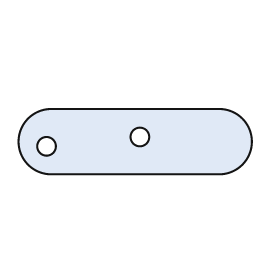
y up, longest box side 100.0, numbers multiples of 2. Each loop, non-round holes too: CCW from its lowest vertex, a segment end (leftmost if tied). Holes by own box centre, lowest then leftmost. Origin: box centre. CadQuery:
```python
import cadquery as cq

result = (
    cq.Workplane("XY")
    .moveTo(-36.0, -14.0)
    .lineTo(36.0, -14.0)
    .threePointArc((50.0, 0.0), (36.0, 14.0))
    .lineTo(-36.0, 14.0)
    .threePointArc((-50.0, 0.0), (-36.0, -14.0))
    .close()
    .moveTo(-38.0, -2.0)
    .circle(4.0)
    .moveTo(2.0, 2.0)
    .circle(4.0)
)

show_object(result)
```